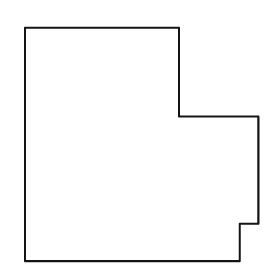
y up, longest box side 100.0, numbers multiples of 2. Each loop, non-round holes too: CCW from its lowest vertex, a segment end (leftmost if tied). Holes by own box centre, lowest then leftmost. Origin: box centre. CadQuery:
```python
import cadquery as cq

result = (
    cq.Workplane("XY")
    .moveTo(-50.0, -50.0)
    .lineTo(42.0, -50.0)
    .lineTo(42.0, -34.0)
    .lineTo(50.0, -34.0)
    .lineTo(50.0, 12.0)
    .lineTo(16.0, 12.0)
    .lineTo(16.0, 50.0)
    .lineTo(-50.0, 50.0)
    .close()
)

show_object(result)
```